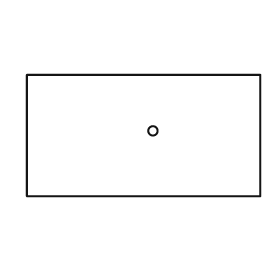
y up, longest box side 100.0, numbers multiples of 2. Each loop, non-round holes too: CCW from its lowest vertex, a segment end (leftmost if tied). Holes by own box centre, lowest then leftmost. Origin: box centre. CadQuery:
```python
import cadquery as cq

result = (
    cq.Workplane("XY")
    .moveTo(-50.0, -26.0)
    .lineTo(50.0, -26.0)
    .lineTo(50.0, 26.0)
    .lineTo(-50.0, 26.0)
    .close()
    .moveTo(4.0, 2.0)
    .circle(2.0)
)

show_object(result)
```